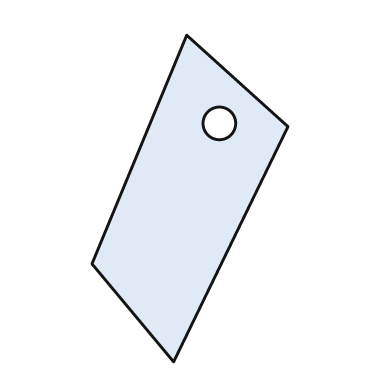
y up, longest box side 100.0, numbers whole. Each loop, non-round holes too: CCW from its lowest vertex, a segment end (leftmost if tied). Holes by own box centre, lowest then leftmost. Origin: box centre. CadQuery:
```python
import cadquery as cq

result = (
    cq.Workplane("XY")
    .moveTo(-5.0, -50.0)
    .lineTo(30.0, 22.0)
    .lineTo(-1.0, 50.0)
    .lineTo(-30.0, -20.0)
    .close()
    .moveTo(9.0, 23.0)
    .circle(5.0)
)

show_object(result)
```